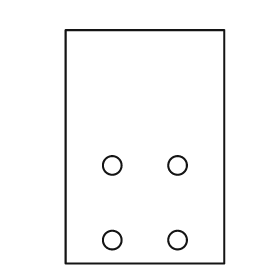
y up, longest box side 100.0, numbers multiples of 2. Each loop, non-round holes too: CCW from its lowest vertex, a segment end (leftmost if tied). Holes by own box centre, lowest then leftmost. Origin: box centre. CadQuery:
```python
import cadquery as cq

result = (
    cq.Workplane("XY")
    .moveTo(-34.0, -50.0)
    .lineTo(34.0, -50.0)
    .lineTo(34.0, 50.0)
    .lineTo(-34.0, 50.0)
    .close()
    .moveTo(-14.0, -40.0)
    .circle(4.0)
    .moveTo(14.0, -40.0)
    .circle(4.0)
    .moveTo(-14.0, -8.0)
    .circle(4.0)
    .moveTo(14.0, -8.0)
    .circle(4.0)
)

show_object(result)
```